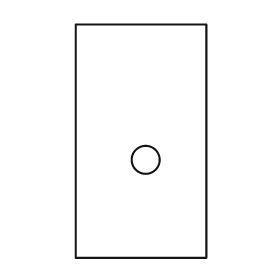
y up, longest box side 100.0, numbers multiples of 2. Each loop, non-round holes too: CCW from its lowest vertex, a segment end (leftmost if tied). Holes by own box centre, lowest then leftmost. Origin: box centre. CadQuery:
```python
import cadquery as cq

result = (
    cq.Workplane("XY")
    .moveTo(-28.0, -50.0)
    .lineTo(28.0, -50.0)
    .lineTo(28.0, 50.0)
    .lineTo(-28.0, 50.0)
    .close()
    .moveTo(2.0, -8.0)
    .circle(6.0)
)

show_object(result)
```